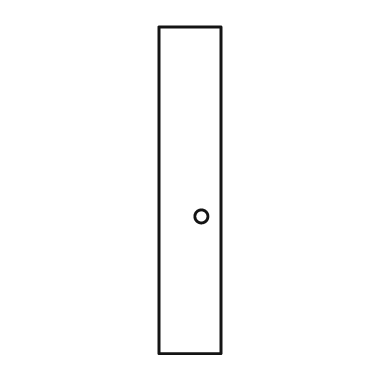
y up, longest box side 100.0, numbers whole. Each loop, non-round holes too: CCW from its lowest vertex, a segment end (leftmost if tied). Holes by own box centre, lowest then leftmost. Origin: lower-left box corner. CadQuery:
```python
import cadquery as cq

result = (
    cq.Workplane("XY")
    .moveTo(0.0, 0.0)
    .lineTo(19.0, 0.0)
    .lineTo(19.0, 100.0)
    .lineTo(0.0, 100.0)
    .close()
    .moveTo(13.0, 42.0)
    .circle(2.0)
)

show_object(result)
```